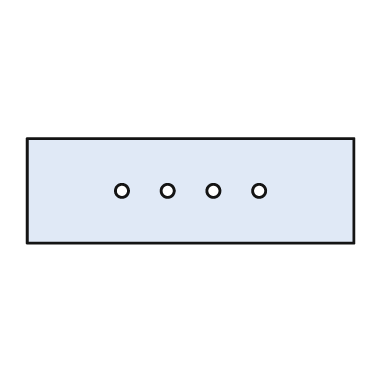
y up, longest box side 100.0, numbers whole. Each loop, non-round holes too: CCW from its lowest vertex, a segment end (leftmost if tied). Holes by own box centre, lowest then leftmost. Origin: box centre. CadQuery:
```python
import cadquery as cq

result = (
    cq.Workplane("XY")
    .moveTo(-50.0, -16.0)
    .lineTo(50.0, -16.0)
    .lineTo(50.0, 16.0)
    .lineTo(-50.0, 16.0)
    .close()
    .moveTo(-21.0, 0.0)
    .circle(2.0)
    .moveTo(-7.0, 0.0)
    .circle(2.0)
    .moveTo(7.0, 0.0)
    .circle(2.0)
    .moveTo(21.0, 0.0)
    .circle(2.0)
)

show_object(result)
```